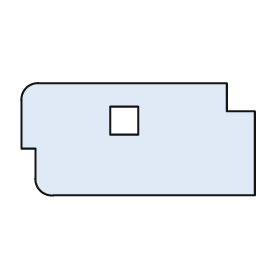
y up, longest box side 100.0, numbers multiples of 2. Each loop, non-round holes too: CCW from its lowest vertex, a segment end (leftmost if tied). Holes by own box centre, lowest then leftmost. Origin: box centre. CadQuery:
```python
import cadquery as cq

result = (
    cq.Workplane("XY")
    .moveTo(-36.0, -24.0)
    .lineTo(50.0, -24.0)
    .lineTo(50.0, 12.0)
    .lineTo(38.0, 12.0)
    .lineTo(38.0, 24.0)
    .lineTo(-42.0, 24.0)
    .threePointArc((-48.0, 22.0), (-50.0, 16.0))
    .lineTo(-50.0, -4.0)
    .lineTo(-44.0, -4.0)
    .lineTo(-44.0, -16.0)
    .threePointArc((-42.0, -22.0), (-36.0, -24.0))
    .close()
    .moveTo(-12.0, 2.0)
    .lineTo(0.0, 2.0)
    .lineTo(0.0, 14.0)
    .lineTo(-12.0, 14.0)
    .close()
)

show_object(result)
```